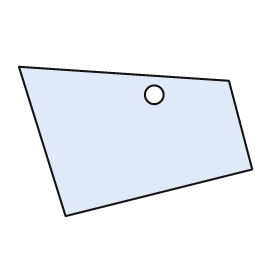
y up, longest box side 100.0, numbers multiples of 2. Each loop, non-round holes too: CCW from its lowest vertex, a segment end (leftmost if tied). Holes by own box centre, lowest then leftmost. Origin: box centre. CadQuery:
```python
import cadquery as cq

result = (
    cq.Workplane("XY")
    .moveTo(-30.0, -32.0)
    .lineTo(50.0, -12.0)
    .lineTo(40.0, 26.0)
    .lineTo(-50.0, 32.0)
    .close()
    .moveTo(8.0, 20.0)
    .circle(4.0)
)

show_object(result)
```